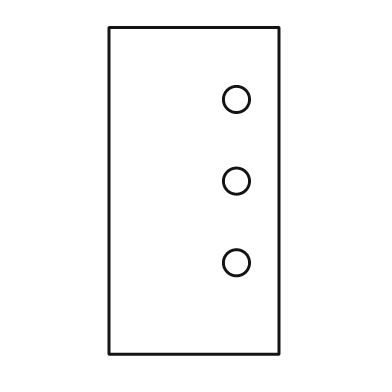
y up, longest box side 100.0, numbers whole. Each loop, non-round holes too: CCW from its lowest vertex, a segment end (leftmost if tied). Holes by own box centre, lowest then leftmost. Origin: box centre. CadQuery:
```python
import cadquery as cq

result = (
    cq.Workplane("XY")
    .moveTo(-26.0, -50.0)
    .lineTo(26.0, -50.0)
    .lineTo(26.0, 50.0)
    .lineTo(-26.0, 50.0)
    .close()
    .moveTo(13.0, -22.0)
    .circle(4.0)
    .moveTo(13.0, 3.0)
    .circle(4.0)
    .moveTo(13.0, 28.0)
    .circle(4.0)
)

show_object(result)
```